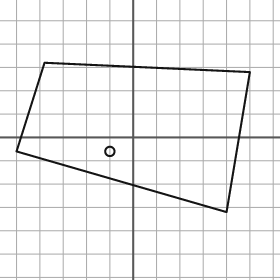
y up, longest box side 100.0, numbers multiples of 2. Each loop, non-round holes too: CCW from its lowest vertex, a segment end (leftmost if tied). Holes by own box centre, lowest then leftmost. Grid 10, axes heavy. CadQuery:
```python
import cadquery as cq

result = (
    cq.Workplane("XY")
    .moveTo(40.0, -32.0)
    .lineTo(50.0, 28.0)
    .lineTo(-38.0, 32.0)
    .lineTo(-50.0, -6.0)
    .close()
    .moveTo(-10.0, -6.0)
    .circle(2.0)
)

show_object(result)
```